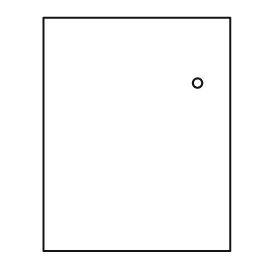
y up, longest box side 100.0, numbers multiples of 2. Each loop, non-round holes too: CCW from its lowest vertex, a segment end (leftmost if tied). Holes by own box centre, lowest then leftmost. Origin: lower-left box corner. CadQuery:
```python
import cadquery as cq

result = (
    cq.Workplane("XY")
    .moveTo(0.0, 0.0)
    .lineTo(80.0, 0.0)
    .lineTo(80.0, 100.0)
    .lineTo(0.0, 100.0)
    .close()
    .moveTo(66.0, 72.0)
    .circle(2.0)
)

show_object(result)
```